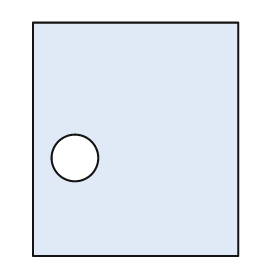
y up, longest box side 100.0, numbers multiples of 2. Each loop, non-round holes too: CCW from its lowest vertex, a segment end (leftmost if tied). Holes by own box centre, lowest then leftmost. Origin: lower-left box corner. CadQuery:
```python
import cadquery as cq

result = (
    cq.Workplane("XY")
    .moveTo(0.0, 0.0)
    .lineTo(88.0, 0.0)
    .lineTo(88.0, 100.0)
    .lineTo(0.0, 100.0)
    .close()
    .moveTo(18.0, 42.0)
    .circle(10.0)
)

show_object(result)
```